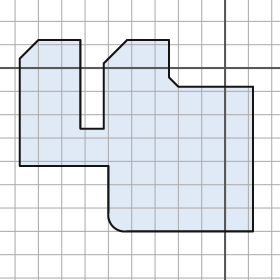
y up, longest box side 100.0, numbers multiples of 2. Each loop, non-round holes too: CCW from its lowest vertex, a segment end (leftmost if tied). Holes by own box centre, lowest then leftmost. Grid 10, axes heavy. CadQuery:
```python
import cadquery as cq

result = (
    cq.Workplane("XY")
    .moveTo(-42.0, -70.0)
    .lineTo(12.0, -70.0)
    .lineTo(12.0, -8.0)
    .lineTo(-20.0, -8.0)
    .lineTo(-24.0, -4.0)
    .lineTo(-24.0, 12.0)
    .lineTo(-42.0, 12.0)
    .lineTo(-52.0, 2.0)
    .lineTo(-52.0, -26.0)
    .lineTo(-62.0, -26.0)
    .lineTo(-62.0, 12.0)
    .lineTo(-80.0, 12.0)
    .lineTo(-88.0, 4.0)
    .lineTo(-88.0, -42.0)
    .lineTo(-50.0, -42.0)
    .lineTo(-50.0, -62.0)
    .threePointArc((-48.0, -68.0), (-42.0, -70.0))
    .close()
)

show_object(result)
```